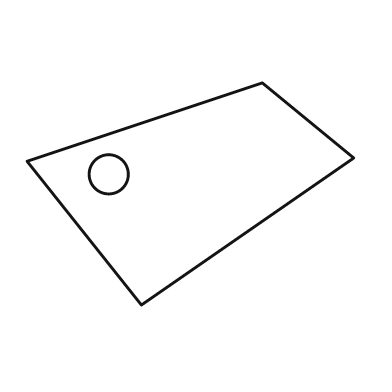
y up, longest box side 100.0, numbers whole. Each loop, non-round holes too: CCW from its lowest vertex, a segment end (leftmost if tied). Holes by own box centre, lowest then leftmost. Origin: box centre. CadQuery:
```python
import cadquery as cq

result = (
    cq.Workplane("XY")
    .moveTo(-15.0, -34.0)
    .lineTo(50.0, 11.0)
    .lineTo(22.0, 34.0)
    .lineTo(-50.0, 10.0)
    .close()
    .moveTo(-25.0, 6.0)
    .circle(6.0)
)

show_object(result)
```